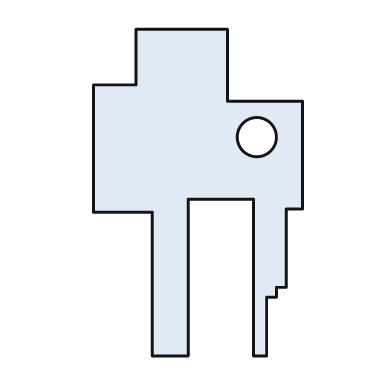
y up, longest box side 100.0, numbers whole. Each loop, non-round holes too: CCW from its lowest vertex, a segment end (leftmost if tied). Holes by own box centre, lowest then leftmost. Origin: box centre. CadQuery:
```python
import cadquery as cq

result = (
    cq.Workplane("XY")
    .moveTo(-14.0, -50.0)
    .lineTo(-3.0, -50.0)
    .lineTo(-3.0, -2.0)
    .lineTo(17.0, -2.0)
    .lineTo(17.0, -50.0)
    .lineTo(21.0, -50.0)
    .lineTo(21.0, -32.0)
    .lineTo(24.0, -32.0)
    .lineTo(24.0, -29.0)
    .lineTo(27.0, -29.0)
    .lineTo(27.0, -5.0)
    .lineTo(32.0, -5.0)
    .lineTo(32.0, 28.0)
    .lineTo(9.0, 28.0)
    .lineTo(9.0, 50.0)
    .lineTo(-19.0, 50.0)
    .lineTo(-19.0, 33.0)
    .lineTo(-32.0, 33.0)
    .lineTo(-32.0, -6.0)
    .lineTo(-14.0, -6.0)
    .close()
    .moveTo(18.0, 17.0)
    .circle(6.0)
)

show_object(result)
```